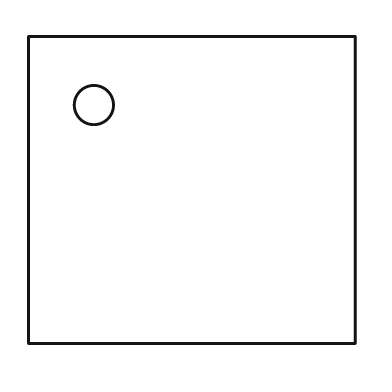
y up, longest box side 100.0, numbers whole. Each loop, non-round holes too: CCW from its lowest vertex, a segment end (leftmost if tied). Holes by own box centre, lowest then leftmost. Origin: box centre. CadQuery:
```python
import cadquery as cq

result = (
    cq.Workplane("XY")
    .moveTo(-50.0, -47.0)
    .lineTo(50.0, -47.0)
    .lineTo(50.0, 47.0)
    .lineTo(-50.0, 47.0)
    .close()
    .moveTo(-30.0, 26.0)
    .circle(6.0)
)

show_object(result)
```